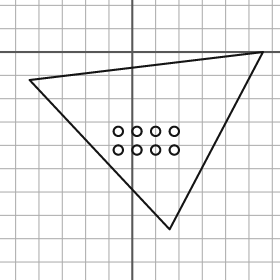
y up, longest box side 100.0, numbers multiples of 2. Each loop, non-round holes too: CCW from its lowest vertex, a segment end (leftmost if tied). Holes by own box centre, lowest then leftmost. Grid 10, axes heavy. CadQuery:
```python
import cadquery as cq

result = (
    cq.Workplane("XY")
    .moveTo(16.0, -76.0)
    .lineTo(56.0, 0.0)
    .lineTo(-44.0, -12.0)
    .close()
    .moveTo(-6.0, -42.0)
    .circle(2.0)
    .moveTo(2.0, -42.0)
    .circle(2.0)
    .moveTo(10.0, -42.0)
    .circle(2.0)
    .moveTo(18.0, -42.0)
    .circle(2.0)
    .moveTo(-6.0, -34.0)
    .circle(2.0)
    .moveTo(2.0, -34.0)
    .circle(2.0)
    .moveTo(10.0, -34.0)
    .circle(2.0)
    .moveTo(18.0, -34.0)
    .circle(2.0)
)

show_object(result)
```